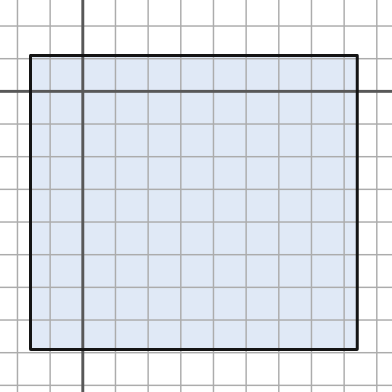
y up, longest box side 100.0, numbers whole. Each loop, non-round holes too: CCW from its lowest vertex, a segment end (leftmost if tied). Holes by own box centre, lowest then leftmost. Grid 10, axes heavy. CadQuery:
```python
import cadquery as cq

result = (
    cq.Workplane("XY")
    .moveTo(-16.0, -79.0)
    .lineTo(84.0, -79.0)
    .lineTo(84.0, 11.0)
    .lineTo(-16.0, 11.0)
    .close()
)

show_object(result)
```